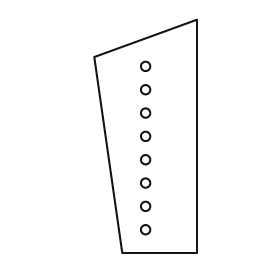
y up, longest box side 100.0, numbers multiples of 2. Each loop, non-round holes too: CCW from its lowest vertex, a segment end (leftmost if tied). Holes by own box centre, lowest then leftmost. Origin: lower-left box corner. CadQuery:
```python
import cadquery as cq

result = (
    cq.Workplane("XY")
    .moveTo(12.0, 0.0)
    .lineTo(44.0, 0.0)
    .lineTo(44.0, 100.0)
    .lineTo(0.0, 84.0)
    .close()
    .moveTo(22.0, 10.0)
    .circle(2.0)
    .moveTo(22.0, 20.0)
    .circle(2.0)
    .moveTo(22.0, 30.0)
    .circle(2.0)
    .moveTo(22.0, 40.0)
    .circle(2.0)
    .moveTo(22.0, 50.0)
    .circle(2.0)
    .moveTo(22.0, 60.0)
    .circle(2.0)
    .moveTo(22.0, 70.0)
    .circle(2.0)
    .moveTo(22.0, 80.0)
    .circle(2.0)
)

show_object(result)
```